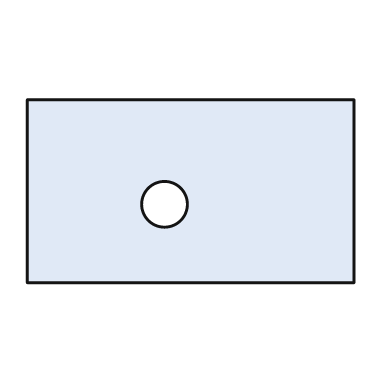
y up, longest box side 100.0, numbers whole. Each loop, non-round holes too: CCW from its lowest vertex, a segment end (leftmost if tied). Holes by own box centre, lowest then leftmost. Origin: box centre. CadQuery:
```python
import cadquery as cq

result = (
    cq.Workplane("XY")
    .moveTo(-50.0, -28.0)
    .lineTo(50.0, -28.0)
    .lineTo(50.0, 28.0)
    .lineTo(-50.0, 28.0)
    .close()
    .moveTo(-8.0, -4.0)
    .circle(7.0)
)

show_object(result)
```